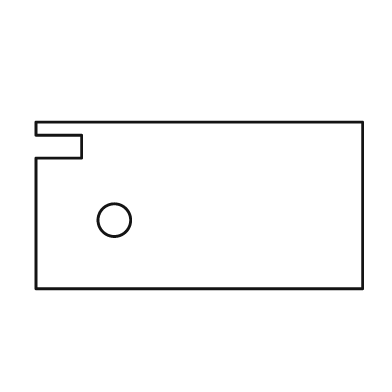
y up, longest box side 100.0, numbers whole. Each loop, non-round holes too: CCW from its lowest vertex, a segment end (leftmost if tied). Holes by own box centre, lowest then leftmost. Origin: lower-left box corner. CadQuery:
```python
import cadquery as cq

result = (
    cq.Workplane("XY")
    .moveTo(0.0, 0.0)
    .lineTo(100.0, 0.0)
    .lineTo(100.0, 51.0)
    .lineTo(0.0, 51.0)
    .lineTo(0.0, 47.0)
    .lineTo(14.0, 47.0)
    .lineTo(14.0, 40.0)
    .lineTo(0.0, 40.0)
    .close()
    .moveTo(24.0, 21.0)
    .circle(5.0)
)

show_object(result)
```